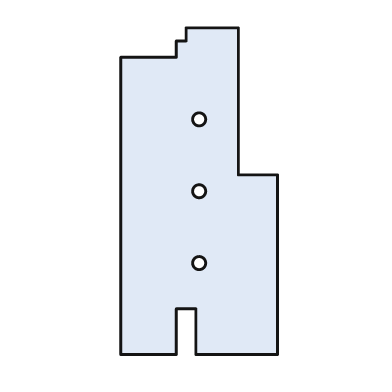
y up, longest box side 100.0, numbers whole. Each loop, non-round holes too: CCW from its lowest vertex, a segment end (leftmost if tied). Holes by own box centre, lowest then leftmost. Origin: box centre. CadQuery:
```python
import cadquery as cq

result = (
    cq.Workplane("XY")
    .moveTo(-24.0, -50.0)
    .lineTo(-7.0, -50.0)
    .lineTo(-7.0, -36.0)
    .lineTo(-1.0, -36.0)
    .lineTo(-1.0, -50.0)
    .lineTo(24.0, -50.0)
    .lineTo(24.0, 5.0)
    .lineTo(12.0, 5.0)
    .lineTo(12.0, 50.0)
    .lineTo(-4.0, 50.0)
    .lineTo(-4.0, 46.0)
    .lineTo(-7.0, 46.0)
    .lineTo(-7.0, 41.0)
    .lineTo(-24.0, 41.0)
    .close()
    .moveTo(0.0, -22.0)
    .circle(2.0)
    .moveTo(0.0, 0.0)
    .circle(2.0)
    .moveTo(0.0, 22.0)
    .circle(2.0)
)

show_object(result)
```